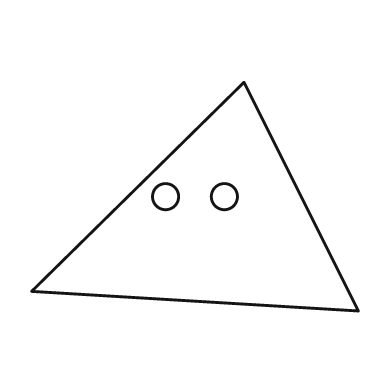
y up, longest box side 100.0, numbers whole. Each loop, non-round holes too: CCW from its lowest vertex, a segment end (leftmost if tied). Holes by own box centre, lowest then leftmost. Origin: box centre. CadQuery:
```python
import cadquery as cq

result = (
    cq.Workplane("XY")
    .moveTo(50.0, -35.0)
    .lineTo(15.0, 35.0)
    .lineTo(-50.0, -29.0)
    .close()
    .moveTo(-9.0, 0.0)
    .circle(4.0)
    .moveTo(9.0, 0.0)
    .circle(4.0)
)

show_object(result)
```